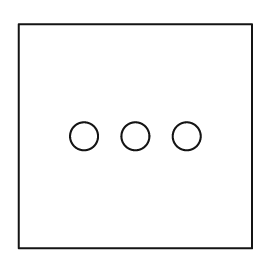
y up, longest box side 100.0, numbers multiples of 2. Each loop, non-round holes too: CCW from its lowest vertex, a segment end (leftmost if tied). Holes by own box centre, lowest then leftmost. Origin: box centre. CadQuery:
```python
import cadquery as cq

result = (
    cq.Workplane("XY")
    .moveTo(-50.0, -48.0)
    .lineTo(50.0, -48.0)
    .lineTo(50.0, 48.0)
    .lineTo(-50.0, 48.0)
    .close()
    .moveTo(-22.0, 0.0)
    .circle(6.0)
    .moveTo(0.0, 0.0)
    .circle(6.0)
    .moveTo(22.0, 0.0)
    .circle(6.0)
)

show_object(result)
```